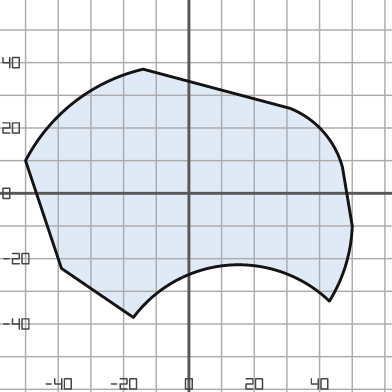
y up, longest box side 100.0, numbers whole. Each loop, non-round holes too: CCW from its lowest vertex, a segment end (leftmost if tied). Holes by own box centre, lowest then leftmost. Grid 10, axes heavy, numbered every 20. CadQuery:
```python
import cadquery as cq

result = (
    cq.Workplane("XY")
    .moveTo(-17.0, -38.0)
    .threePointArc((12.0, -22.0), (43.0, -33.0))
    .threePointArc((48.0, -22.0), (50.0, -10.0))
    .lineTo(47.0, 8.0)
    .threePointArc((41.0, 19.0), (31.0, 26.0))
    .lineTo(-14.0, 38.0)
    .threePointArc((-35.0, 28.0), (-50.0, 10.0))
    .lineTo(-39.0, -23.0)
    .close()
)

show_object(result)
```